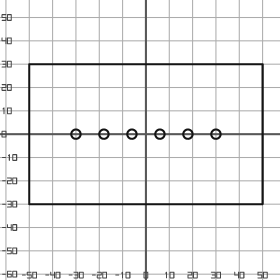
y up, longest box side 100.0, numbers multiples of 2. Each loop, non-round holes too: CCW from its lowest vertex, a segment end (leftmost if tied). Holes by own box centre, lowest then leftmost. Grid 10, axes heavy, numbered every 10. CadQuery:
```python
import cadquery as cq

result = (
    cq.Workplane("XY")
    .moveTo(-50.0, -30.0)
    .lineTo(50.0, -30.0)
    .lineTo(50.0, 30.0)
    .lineTo(-50.0, 30.0)
    .close()
    .moveTo(-30.0, 0.0)
    .circle(2.0)
    .moveTo(-18.0, 0.0)
    .circle(2.0)
    .moveTo(-6.0, 0.0)
    .circle(2.0)
    .moveTo(6.0, 0.0)
    .circle(2.0)
    .moveTo(18.0, 0.0)
    .circle(2.0)
    .moveTo(30.0, 0.0)
    .circle(2.0)
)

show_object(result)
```